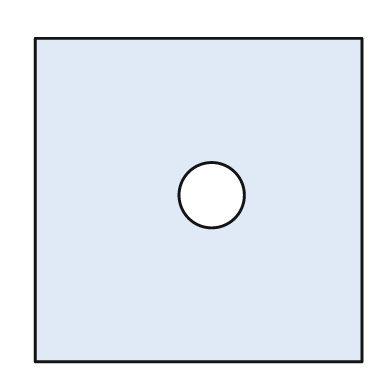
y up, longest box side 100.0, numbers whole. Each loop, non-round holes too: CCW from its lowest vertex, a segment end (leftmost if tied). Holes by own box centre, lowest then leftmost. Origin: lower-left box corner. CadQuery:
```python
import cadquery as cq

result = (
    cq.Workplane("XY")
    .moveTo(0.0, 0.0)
    .lineTo(100.0, 0.0)
    .lineTo(100.0, 99.0)
    .lineTo(0.0, 99.0)
    .close()
    .moveTo(54.0, 51.0)
    .circle(10.0)
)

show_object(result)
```